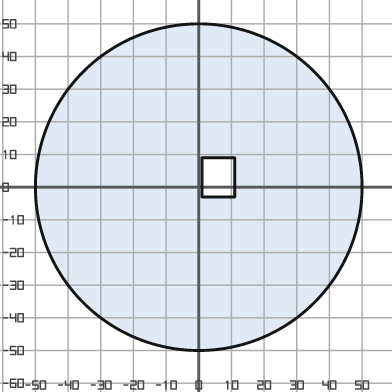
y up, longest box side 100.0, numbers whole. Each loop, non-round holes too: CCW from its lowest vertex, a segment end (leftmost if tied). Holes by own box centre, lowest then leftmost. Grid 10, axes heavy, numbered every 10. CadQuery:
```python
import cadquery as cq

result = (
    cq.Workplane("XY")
    .moveTo(0.0, 0.0)
    .circle(50.0)
    .moveTo(1.0, -3.0)
    .lineTo(11.0, -3.0)
    .lineTo(11.0, 9.0)
    .lineTo(1.0, 9.0)
    .close()
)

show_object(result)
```